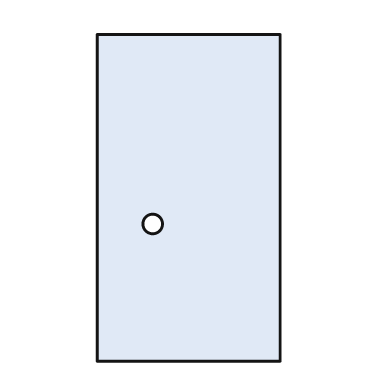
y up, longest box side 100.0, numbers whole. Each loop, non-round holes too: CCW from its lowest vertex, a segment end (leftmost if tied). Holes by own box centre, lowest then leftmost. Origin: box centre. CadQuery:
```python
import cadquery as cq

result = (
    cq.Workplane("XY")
    .moveTo(-28.0, -50.0)
    .lineTo(28.0, -50.0)
    .lineTo(28.0, 50.0)
    .lineTo(-28.0, 50.0)
    .close()
    .moveTo(-11.0, -8.0)
    .circle(3.0)
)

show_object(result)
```